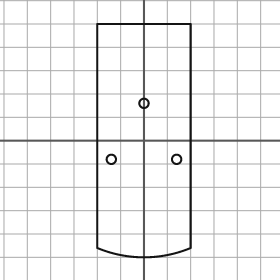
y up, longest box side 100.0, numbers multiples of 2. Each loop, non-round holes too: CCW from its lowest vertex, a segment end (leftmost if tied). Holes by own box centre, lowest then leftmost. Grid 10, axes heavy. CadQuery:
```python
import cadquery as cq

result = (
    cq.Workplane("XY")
    .moveTo(-20.0, -46.0)
    .threePointArc((0.0, -50.0), (20.0, -46.0))
    .lineTo(20.0, 50.0)
    .lineTo(-20.0, 50.0)
    .close()
    .moveTo(-14.0, -8.0)
    .circle(2.0)
    .moveTo(14.0, -8.0)
    .circle(2.0)
    .moveTo(0.0, 16.0)
    .circle(2.0)
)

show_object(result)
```